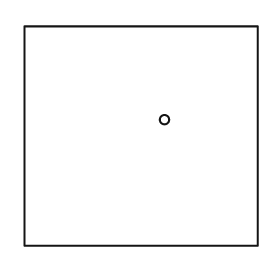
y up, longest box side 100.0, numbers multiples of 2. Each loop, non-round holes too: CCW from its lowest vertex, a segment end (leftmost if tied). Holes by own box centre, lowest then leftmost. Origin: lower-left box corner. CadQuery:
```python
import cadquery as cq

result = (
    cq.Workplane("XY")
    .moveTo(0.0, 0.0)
    .lineTo(100.0, 0.0)
    .lineTo(100.0, 94.0)
    .lineTo(0.0, 94.0)
    .close()
    .moveTo(60.0, 54.0)
    .circle(2.0)
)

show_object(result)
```